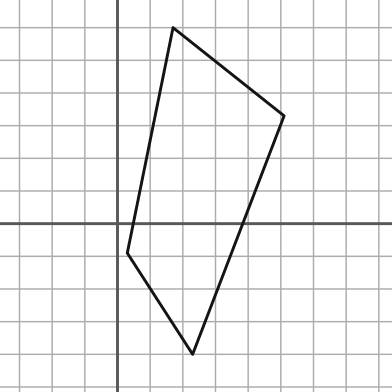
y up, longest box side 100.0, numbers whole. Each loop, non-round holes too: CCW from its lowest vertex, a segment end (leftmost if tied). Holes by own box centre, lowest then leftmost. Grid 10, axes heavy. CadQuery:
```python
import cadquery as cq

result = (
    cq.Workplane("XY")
    .moveTo(23.0, -40.0)
    .lineTo(51.0, 33.0)
    .lineTo(17.0, 60.0)
    .lineTo(3.0, -9.0)
    .close()
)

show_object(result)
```